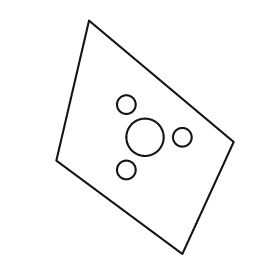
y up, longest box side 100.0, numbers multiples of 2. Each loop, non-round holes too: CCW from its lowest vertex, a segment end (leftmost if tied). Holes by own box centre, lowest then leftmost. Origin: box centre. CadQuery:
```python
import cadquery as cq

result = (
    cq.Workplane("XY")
    .moveTo(16.0, -50.0)
    .lineTo(38.0, -2.0)
    .lineTo(-24.0, 50.0)
    .lineTo(-38.0, -10.0)
    .close()
    .moveTo(-8.0, -14.0)
    .circle(4.0)
    .moveTo(0.0, 0.0)
    .circle(8.0)
    .moveTo(16.0, 0.0)
    .circle(4.0)
    .moveTo(-8.0, 14.0)
    .circle(4.0)
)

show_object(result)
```